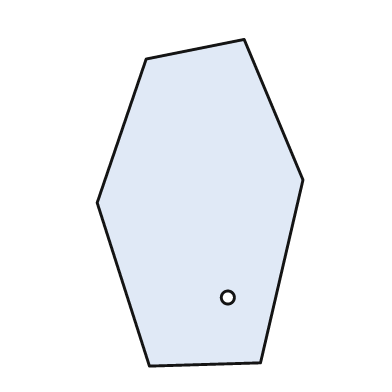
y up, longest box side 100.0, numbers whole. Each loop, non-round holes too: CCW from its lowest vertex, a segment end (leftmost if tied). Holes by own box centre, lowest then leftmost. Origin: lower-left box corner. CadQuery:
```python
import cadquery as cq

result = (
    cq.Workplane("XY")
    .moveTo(16.0, 0.0)
    .lineTo(50.0, 1.0)
    .lineTo(63.0, 57.0)
    .lineTo(45.0, 100.0)
    .lineTo(15.0, 94.0)
    .lineTo(0.0, 50.0)
    .close()
    .moveTo(40.0, 21.0)
    .circle(2.0)
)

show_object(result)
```